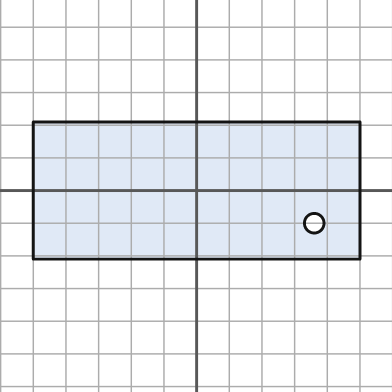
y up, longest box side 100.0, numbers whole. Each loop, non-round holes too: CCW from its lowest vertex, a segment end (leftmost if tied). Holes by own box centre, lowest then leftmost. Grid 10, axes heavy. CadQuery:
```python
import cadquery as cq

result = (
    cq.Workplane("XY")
    .moveTo(-50.0, -21.0)
    .lineTo(50.0, -21.0)
    .lineTo(50.0, 21.0)
    .lineTo(-50.0, 21.0)
    .close()
    .moveTo(36.0, -10.0)
    .circle(3.0)
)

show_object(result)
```